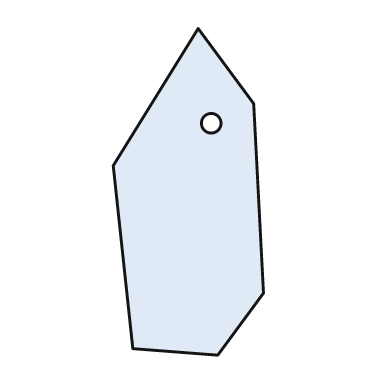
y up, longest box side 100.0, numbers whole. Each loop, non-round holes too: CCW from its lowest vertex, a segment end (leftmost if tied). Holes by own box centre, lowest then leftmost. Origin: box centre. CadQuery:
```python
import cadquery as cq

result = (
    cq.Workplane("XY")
    .moveTo(9.0, -50.0)
    .lineTo(23.0, -31.0)
    .lineTo(20.0, 27.0)
    .lineTo(3.0, 50.0)
    .lineTo(-23.0, 8.0)
    .lineTo(-17.0, -48.0)
    .close()
    .moveTo(7.0, 21.0)
    .circle(3.0)
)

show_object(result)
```